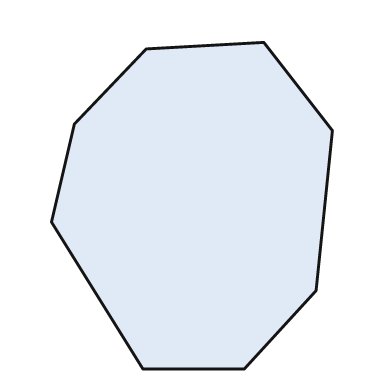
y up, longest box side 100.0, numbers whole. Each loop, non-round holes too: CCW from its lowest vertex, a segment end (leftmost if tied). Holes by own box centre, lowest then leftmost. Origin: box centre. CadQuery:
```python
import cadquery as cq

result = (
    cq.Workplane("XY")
    .moveTo(-15.0, -50.0)
    .lineTo(16.0, -50.0)
    .lineTo(38.0, -26.0)
    .lineTo(43.0, 23.0)
    .lineTo(22.0, 50.0)
    .lineTo(-14.0, 48.0)
    .lineTo(-36.0, 25.0)
    .lineTo(-43.0, -5.0)
    .close()
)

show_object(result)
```